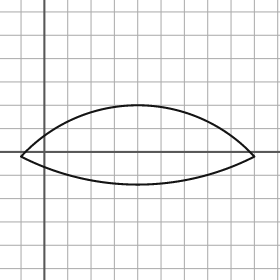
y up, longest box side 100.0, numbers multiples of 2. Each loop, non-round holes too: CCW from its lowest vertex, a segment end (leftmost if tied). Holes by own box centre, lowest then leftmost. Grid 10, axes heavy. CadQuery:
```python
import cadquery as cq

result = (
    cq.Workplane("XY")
    .moveTo(-10.0, -2.0)
    .threePointArc((40.0, -14.0), (90.0, -2.0))
    .threePointArc((40.0, 20.0), (-10.0, -2.0))
    .close()
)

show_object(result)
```